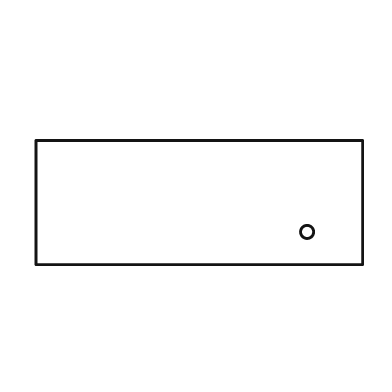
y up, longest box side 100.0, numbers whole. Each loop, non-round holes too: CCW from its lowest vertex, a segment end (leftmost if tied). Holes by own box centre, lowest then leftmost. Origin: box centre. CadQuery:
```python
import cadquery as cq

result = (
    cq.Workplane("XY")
    .moveTo(-50.0, -19.0)
    .lineTo(50.0, -19.0)
    .lineTo(50.0, 19.0)
    .lineTo(-50.0, 19.0)
    .close()
    .moveTo(33.0, -9.0)
    .circle(2.0)
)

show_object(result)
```